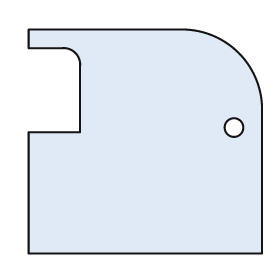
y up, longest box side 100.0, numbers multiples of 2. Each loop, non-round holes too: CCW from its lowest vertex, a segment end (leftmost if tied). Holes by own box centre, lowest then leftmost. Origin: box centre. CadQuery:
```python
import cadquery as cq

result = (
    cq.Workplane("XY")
    .moveTo(-50.0, -48.0)
    .lineTo(50.0, -48.0)
    .lineTo(50.0, 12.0)
    .threePointArc((40.0, 38.0), (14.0, 48.0))
    .lineTo(-50.0, 48.0)
    .lineTo(-50.0, 40.0)
    .lineTo(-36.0, 40.0)
    .threePointArc((-30.0, 38.0), (-28.0, 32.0))
    .lineTo(-28.0, 4.0)
    .lineTo(-50.0, 4.0)
    .close()
    .moveTo(38.0, 6.0)
    .circle(4.0)
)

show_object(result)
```